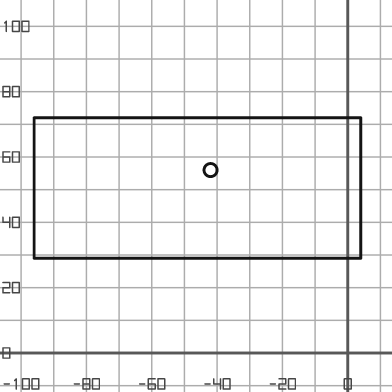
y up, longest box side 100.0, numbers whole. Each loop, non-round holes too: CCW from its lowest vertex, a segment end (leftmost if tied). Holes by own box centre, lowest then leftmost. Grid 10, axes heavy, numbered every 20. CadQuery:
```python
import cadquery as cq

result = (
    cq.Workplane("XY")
    .moveTo(-96.0, 29.0)
    .lineTo(4.0, 29.0)
    .lineTo(4.0, 72.0)
    .lineTo(-96.0, 72.0)
    .close()
    .moveTo(-42.0, 56.0)
    .circle(2.0)
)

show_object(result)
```